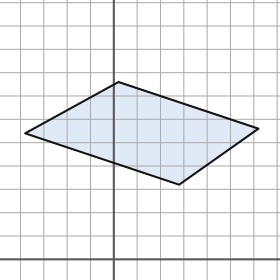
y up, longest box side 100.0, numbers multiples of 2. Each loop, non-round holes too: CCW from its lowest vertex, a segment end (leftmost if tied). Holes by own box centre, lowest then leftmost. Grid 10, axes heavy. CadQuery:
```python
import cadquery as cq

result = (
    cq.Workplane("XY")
    .moveTo(28.0, 32.0)
    .lineTo(62.0, 56.0)
    .lineTo(2.0, 76.0)
    .lineTo(-38.0, 54.0)
    .close()
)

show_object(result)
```